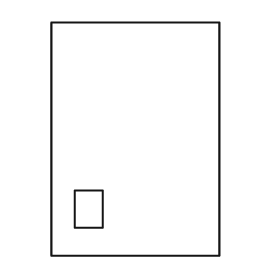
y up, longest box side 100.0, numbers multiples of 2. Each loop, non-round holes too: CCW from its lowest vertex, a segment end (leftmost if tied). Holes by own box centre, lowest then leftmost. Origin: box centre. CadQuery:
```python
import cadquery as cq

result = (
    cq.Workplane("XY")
    .moveTo(-36.0, -50.0)
    .lineTo(36.0, -50.0)
    .lineTo(36.0, 50.0)
    .lineTo(-36.0, 50.0)
    .close()
    .moveTo(-26.0, -38.0)
    .lineTo(-14.0, -38.0)
    .lineTo(-14.0, -22.0)
    .lineTo(-26.0, -22.0)
    .close()
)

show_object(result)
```